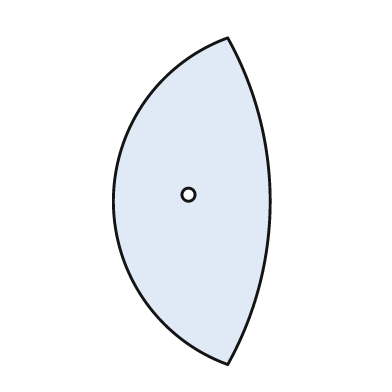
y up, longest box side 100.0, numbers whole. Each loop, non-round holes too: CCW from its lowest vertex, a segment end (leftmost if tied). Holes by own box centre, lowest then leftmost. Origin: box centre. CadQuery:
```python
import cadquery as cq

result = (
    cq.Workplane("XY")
    .moveTo(11.0, -50.0)
    .threePointArc((24.0, 0.0), (11.0, 50.0))
    .threePointArc((-24.0, 0.0), (11.0, -50.0))
    .close()
    .moveTo(-1.0, 2.0)
    .circle(2.0)
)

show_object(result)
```